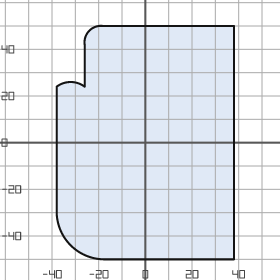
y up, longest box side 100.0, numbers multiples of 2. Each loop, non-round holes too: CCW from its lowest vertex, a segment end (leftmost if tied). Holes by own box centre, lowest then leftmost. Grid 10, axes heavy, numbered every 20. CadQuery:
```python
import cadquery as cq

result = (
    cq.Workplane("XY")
    .moveTo(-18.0, -50.0)
    .lineTo(38.0, -50.0)
    .lineTo(38.0, 50.0)
    .lineTo(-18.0, 50.0)
    .threePointArc((-24.0, 48.0), (-26.0, 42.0))
    .lineTo(-26.0, 24.0)
    .threePointArc((-32.0, 26.0), (-38.0, 24.0))
    .lineTo(-38.0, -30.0)
    .threePointArc((-32.0, -44.0), (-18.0, -50.0))
    .close()
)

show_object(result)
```